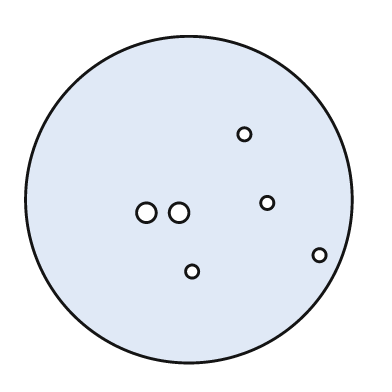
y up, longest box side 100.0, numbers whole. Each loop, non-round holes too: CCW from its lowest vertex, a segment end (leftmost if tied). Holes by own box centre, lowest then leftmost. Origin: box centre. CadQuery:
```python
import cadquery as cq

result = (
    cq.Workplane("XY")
    .moveTo(0.0, 0.0)
    .circle(50.0)
    .moveTo(1.0, -22.0)
    .circle(2.0)
    .moveTo(40.0, -17.0)
    .circle(2.0)
    .moveTo(-13.0, -4.0)
    .circle(3.0)
    .moveTo(-3.0, -4.0)
    .circle(3.0)
    .moveTo(24.0, -1.0)
    .circle(2.0)
    .moveTo(17.0, 20.0)
    .circle(2.0)
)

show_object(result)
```